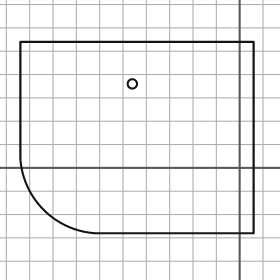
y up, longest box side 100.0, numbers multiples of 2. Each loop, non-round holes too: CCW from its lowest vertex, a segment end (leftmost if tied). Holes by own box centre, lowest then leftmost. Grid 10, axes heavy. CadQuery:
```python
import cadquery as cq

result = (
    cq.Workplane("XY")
    .moveTo(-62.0, -28.0)
    .lineTo(6.0, -28.0)
    .lineTo(6.0, 54.0)
    .lineTo(-94.0, 54.0)
    .lineTo(-94.0, 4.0)
    .threePointArc((-84.0, -18.0), (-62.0, -28.0))
    .close()
    .moveTo(-46.0, 36.0)
    .circle(2.0)
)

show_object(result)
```